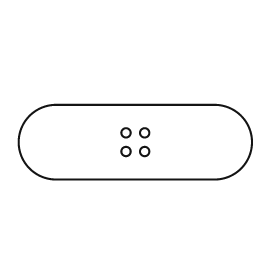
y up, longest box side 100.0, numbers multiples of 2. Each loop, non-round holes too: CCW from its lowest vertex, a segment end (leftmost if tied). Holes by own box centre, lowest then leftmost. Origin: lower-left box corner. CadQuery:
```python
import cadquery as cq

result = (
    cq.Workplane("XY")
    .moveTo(16.0, 0.0)
    .lineTo(84.0, 0.0)
    .threePointArc((100.0, 16.0), (84.0, 32.0))
    .lineTo(16.0, 32.0)
    .threePointArc((0.0, 16.0), (16.0, 0.0))
    .close()
    .moveTo(46.0, 12.0)
    .circle(2.0)
    .moveTo(54.0, 12.0)
    .circle(2.0)
    .moveTo(46.0, 20.0)
    .circle(2.0)
    .moveTo(54.0, 20.0)
    .circle(2.0)
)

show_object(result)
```